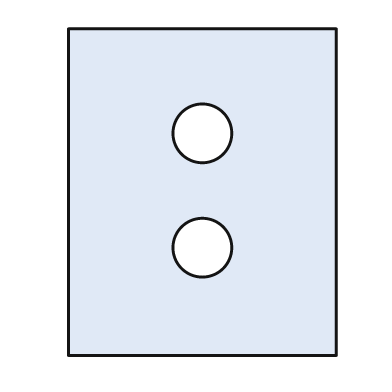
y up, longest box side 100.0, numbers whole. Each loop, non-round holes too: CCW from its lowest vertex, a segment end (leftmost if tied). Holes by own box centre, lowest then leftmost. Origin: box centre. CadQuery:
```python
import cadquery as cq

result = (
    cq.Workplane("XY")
    .moveTo(-41.0, -50.0)
    .lineTo(41.0, -50.0)
    .lineTo(41.0, 50.0)
    .lineTo(-41.0, 50.0)
    .close()
    .moveTo(0.0, -17.0)
    .circle(9.0)
    .moveTo(0.0, 18.0)
    .circle(9.0)
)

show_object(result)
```